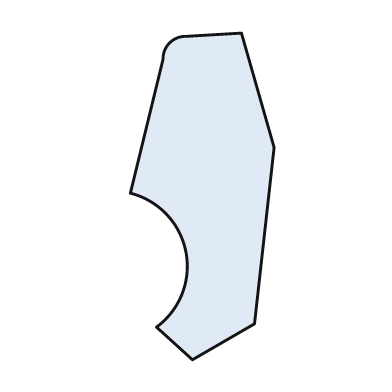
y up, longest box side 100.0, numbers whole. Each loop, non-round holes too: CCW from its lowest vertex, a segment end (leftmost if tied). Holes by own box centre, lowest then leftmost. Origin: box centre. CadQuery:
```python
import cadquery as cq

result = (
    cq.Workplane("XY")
    .moveTo(-3.0, -50.0)
    .lineTo(16.0, -39.0)
    .lineTo(22.0, 15.0)
    .lineTo(12.0, 50.0)
    .lineTo(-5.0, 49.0)
    .threePointArc((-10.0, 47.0), (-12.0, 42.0))
    .lineTo(-22.0, 1.0)
    .threePointArc((-5.0, -17.0), (-14.0, -40.0))
    .close()
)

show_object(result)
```